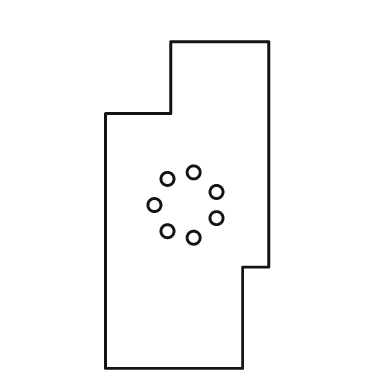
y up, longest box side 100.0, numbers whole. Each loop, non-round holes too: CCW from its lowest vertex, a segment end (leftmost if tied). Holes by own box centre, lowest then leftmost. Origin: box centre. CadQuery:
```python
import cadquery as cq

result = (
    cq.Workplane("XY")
    .moveTo(-25.0, -50.0)
    .lineTo(17.0, -50.0)
    .lineTo(17.0, -19.0)
    .lineTo(25.0, -19.0)
    .lineTo(25.0, 50.0)
    .lineTo(-5.0, 50.0)
    .lineTo(-5.0, 28.0)
    .lineTo(-25.0, 28.0)
    .close()
    .moveTo(2.0, -10.0)
    .circle(2.0)
    .moveTo(-6.0, -8.0)
    .circle(2.0)
    .moveTo(9.0, -4.0)
    .circle(2.0)
    .moveTo(-10.0, 0.0)
    .circle(2.0)
    .moveTo(9.0, 4.0)
    .circle(2.0)
    .moveTo(-6.0, 8.0)
    .circle(2.0)
    .moveTo(2.0, 10.0)
    .circle(2.0)
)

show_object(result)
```